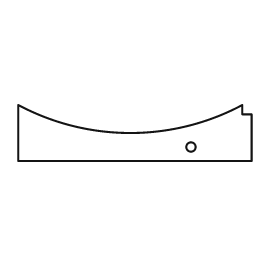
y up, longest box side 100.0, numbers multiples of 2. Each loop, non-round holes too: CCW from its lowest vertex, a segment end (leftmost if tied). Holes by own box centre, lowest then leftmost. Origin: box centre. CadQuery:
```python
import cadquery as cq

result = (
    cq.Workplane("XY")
    .moveTo(-50.0, -12.0)
    .lineTo(50.0, -12.0)
    .lineTo(50.0, 8.0)
    .lineTo(46.0, 8.0)
    .lineTo(46.0, 12.0)
    .threePointArc((-2.0, 0.0), (-50.0, 12.0))
    .close()
    .moveTo(24.0, -6.0)
    .circle(2.0)
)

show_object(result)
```